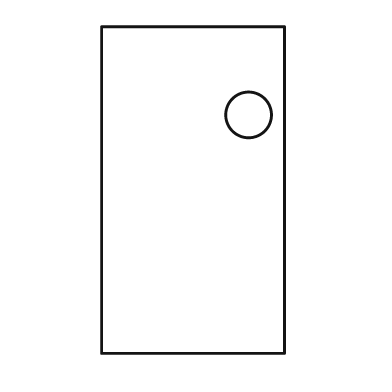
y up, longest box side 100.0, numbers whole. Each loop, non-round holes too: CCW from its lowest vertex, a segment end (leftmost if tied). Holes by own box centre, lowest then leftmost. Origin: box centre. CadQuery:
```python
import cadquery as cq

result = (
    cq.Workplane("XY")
    .moveTo(-28.0, -50.0)
    .lineTo(28.0, -50.0)
    .lineTo(28.0, 50.0)
    .lineTo(-28.0, 50.0)
    .close()
    .moveTo(17.0, 23.0)
    .circle(7.0)
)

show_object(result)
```